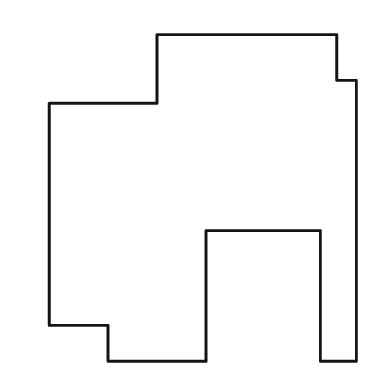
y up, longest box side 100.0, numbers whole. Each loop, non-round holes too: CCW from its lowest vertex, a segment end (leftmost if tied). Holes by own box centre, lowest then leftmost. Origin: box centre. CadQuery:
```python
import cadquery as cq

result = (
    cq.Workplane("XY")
    .moveTo(-29.0, -50.0)
    .lineTo(1.0, -50.0)
    .lineTo(1.0, -10.0)
    .lineTo(36.0, -10.0)
    .lineTo(36.0, -50.0)
    .lineTo(47.0, -50.0)
    .lineTo(47.0, 36.0)
    .lineTo(41.0, 36.0)
    .lineTo(41.0, 50.0)
    .lineTo(-14.0, 50.0)
    .lineTo(-14.0, 29.0)
    .lineTo(-47.0, 29.0)
    .lineTo(-47.0, -39.0)
    .lineTo(-29.0, -39.0)
    .close()
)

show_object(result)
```